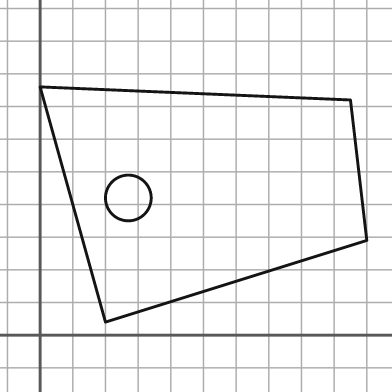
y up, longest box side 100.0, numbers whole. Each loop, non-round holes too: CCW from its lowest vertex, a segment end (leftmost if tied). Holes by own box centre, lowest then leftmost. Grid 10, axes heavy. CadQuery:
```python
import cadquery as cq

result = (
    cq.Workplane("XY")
    .moveTo(20.0, 4.0)
    .lineTo(100.0, 29.0)
    .lineTo(95.0, 72.0)
    .lineTo(0.0, 76.0)
    .close()
    .moveTo(27.0, 42.0)
    .circle(7.0)
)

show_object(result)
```